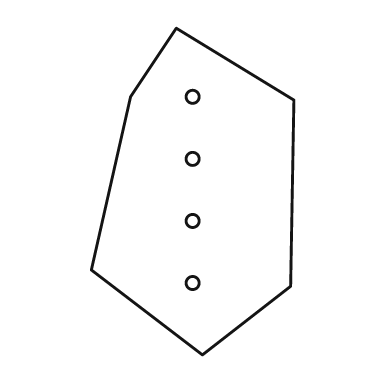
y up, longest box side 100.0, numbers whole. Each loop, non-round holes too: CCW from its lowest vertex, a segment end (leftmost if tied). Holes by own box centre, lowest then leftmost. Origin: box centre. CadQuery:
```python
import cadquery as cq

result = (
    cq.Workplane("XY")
    .moveTo(3.0, -50.0)
    .lineTo(30.0, -29.0)
    .lineTo(31.0, 28.0)
    .lineTo(-5.0, 50.0)
    .lineTo(-19.0, 29.0)
    .lineTo(-31.0, -24.0)
    .close()
    .moveTo(0.0, -28.0)
    .circle(2.0)
    .moveTo(0.0, -9.0)
    .circle(2.0)
    .moveTo(0.0, 10.0)
    .circle(2.0)
    .moveTo(0.0, 29.0)
    .circle(2.0)
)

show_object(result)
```